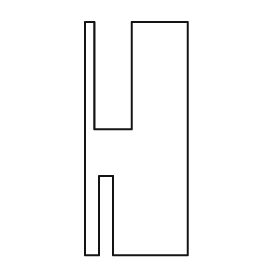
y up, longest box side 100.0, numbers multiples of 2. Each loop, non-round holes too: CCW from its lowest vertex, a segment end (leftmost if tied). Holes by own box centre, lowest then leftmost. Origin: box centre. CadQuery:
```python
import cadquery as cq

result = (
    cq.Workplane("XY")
    .moveTo(-22.0, -50.0)
    .lineTo(-16.0, -50.0)
    .lineTo(-16.0, -16.0)
    .lineTo(-10.0, -16.0)
    .lineTo(-10.0, -50.0)
    .lineTo(22.0, -50.0)
    .lineTo(22.0, 50.0)
    .lineTo(-2.0, 50.0)
    .lineTo(-2.0, 4.0)
    .lineTo(-18.0, 4.0)
    .lineTo(-18.0, 50.0)
    .lineTo(-22.0, 50.0)
    .close()
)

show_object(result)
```